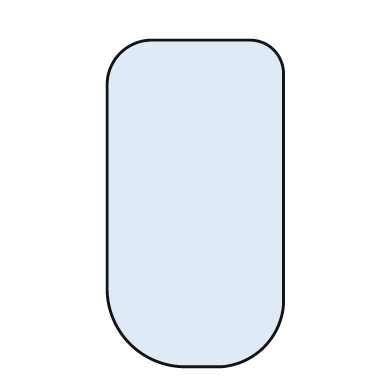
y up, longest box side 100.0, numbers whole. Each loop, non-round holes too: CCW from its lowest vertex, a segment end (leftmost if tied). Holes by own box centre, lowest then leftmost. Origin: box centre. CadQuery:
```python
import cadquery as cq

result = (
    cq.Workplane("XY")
    .moveTo(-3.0, -50.0)
    .lineTo(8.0, -50.0)
    .threePointArc((21.0, -44.0), (27.0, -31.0))
    .lineTo(27.0, 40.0)
    .threePointArc((24.0, 47.0), (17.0, 50.0))
    .lineTo(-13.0, 50.0)
    .threePointArc((-23.0, 46.0), (-27.0, 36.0))
    .lineTo(-27.0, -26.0)
    .threePointArc((-20.0, -43.0), (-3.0, -50.0))
    .close()
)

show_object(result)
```